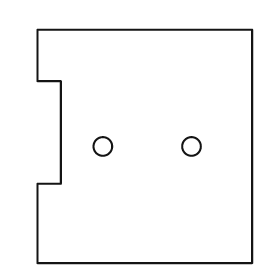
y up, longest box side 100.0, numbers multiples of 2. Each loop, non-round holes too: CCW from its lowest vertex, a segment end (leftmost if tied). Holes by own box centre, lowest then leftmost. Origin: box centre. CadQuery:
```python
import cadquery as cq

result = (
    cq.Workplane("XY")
    .moveTo(-46.0, -50.0)
    .lineTo(46.0, -50.0)
    .lineTo(46.0, 50.0)
    .lineTo(-46.0, 50.0)
    .lineTo(-46.0, 28.0)
    .lineTo(-36.0, 28.0)
    .lineTo(-36.0, -16.0)
    .lineTo(-46.0, -16.0)
    .close()
    .moveTo(-18.0, 0.0)
    .circle(4.0)
    .moveTo(20.0, 0.0)
    .circle(4.0)
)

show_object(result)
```